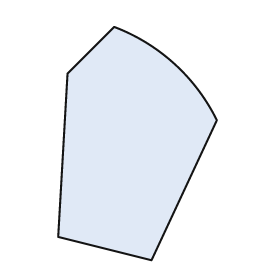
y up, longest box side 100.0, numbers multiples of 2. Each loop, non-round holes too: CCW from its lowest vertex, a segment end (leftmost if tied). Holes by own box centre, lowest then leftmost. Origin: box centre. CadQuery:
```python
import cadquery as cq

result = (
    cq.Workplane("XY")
    .moveTo(6.0, -50.0)
    .lineTo(34.0, 10.0)
    .threePointArc((16.0, 34.0), (-10.0, 50.0))
    .lineTo(-30.0, 30.0)
    .lineTo(-34.0, -40.0)
    .close()
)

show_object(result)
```